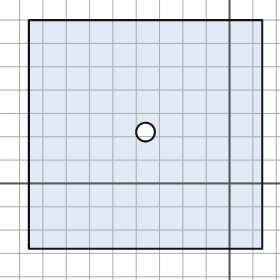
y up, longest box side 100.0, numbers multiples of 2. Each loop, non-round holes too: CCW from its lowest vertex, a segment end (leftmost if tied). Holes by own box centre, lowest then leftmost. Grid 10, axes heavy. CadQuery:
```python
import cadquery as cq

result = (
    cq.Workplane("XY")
    .moveTo(-86.0, -28.0)
    .lineTo(14.0, -28.0)
    .lineTo(14.0, 70.0)
    .lineTo(-86.0, 70.0)
    .close()
    .moveTo(-36.0, 22.0)
    .circle(4.0)
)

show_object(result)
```